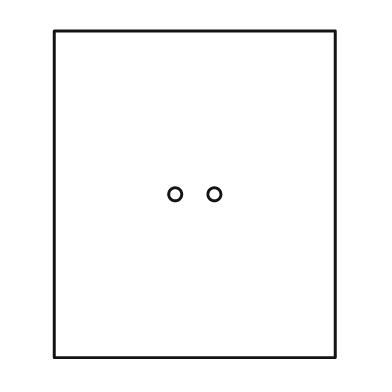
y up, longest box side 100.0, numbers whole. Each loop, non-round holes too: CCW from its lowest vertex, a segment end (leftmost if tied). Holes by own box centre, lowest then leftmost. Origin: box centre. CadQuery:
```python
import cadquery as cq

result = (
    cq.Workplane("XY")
    .moveTo(-43.0, -50.0)
    .lineTo(43.0, -50.0)
    .lineTo(43.0, 50.0)
    .lineTo(-43.0, 50.0)
    .close()
    .moveTo(-6.0, 0.0)
    .circle(2.0)
    .moveTo(6.0, 0.0)
    .circle(2.0)
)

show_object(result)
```